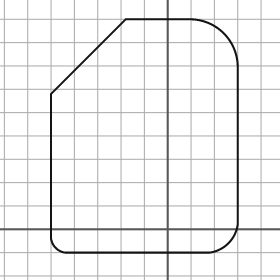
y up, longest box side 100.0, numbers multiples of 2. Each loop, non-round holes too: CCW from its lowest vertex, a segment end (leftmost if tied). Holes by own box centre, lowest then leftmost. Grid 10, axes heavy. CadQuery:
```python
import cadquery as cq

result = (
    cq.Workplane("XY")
    .moveTo(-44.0, -10.0)
    .lineTo(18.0, -10.0)
    .threePointArc((26.0, -6.0), (30.0, 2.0))
    .lineTo(30.0, 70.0)
    .threePointArc((24.0, 84.0), (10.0, 90.0))
    .lineTo(-18.0, 90.0)
    .lineTo(-50.0, 58.0)
    .lineTo(-50.0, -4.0)
    .threePointArc((-48.0, -8.0), (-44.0, -10.0))
    .close()
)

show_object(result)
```